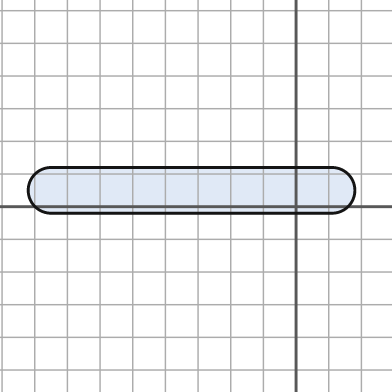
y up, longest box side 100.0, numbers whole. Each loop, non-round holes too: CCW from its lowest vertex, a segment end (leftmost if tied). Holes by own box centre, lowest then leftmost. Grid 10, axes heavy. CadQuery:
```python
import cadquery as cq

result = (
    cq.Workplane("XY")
    .moveTo(-75.0, -2.0)
    .lineTo(11.0, -2.0)
    .threePointArc((18.0, 5.0), (11.0, 12.0))
    .lineTo(-75.0, 12.0)
    .threePointArc((-82.0, 5.0), (-75.0, -2.0))
    .close()
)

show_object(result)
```